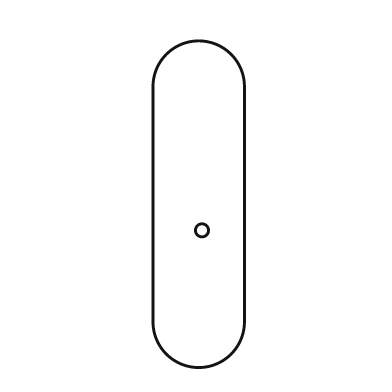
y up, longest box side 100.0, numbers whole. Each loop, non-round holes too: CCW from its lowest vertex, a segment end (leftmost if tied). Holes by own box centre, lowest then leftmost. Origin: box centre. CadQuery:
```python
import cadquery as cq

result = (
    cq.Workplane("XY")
    .moveTo(-14.0, -36.0)
    .threePointArc((0.0, -50.0), (14.0, -36.0))
    .lineTo(14.0, 36.0)
    .threePointArc((0.0, 50.0), (-14.0, 36.0))
    .close()
    .moveTo(1.0, -8.0)
    .circle(2.0)
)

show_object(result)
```